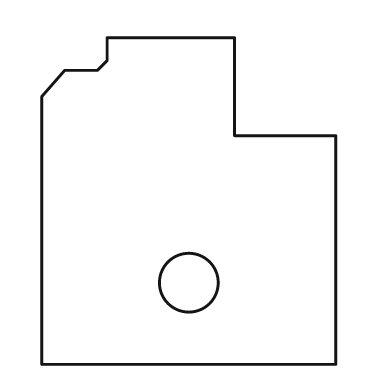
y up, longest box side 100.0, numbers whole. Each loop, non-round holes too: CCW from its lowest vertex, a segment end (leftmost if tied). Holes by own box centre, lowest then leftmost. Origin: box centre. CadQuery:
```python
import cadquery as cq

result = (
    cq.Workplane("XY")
    .moveTo(-45.0, -50.0)
    .lineTo(45.0, -50.0)
    .lineTo(45.0, 20.0)
    .lineTo(14.0, 20.0)
    .lineTo(14.0, 50.0)
    .lineTo(-25.0, 50.0)
    .lineTo(-25.0, 43.0)
    .lineTo(-28.0, 40.0)
    .lineTo(-38.0, 40.0)
    .lineTo(-45.0, 32.0)
    .close()
    .moveTo(0.0, -25.0)
    .circle(9.0)
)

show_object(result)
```